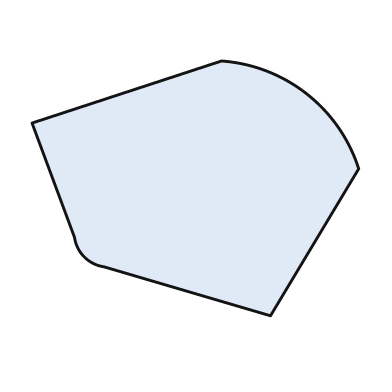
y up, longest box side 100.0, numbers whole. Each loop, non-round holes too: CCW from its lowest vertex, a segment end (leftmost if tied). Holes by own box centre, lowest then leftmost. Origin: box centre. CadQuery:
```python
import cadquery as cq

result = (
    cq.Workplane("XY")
    .moveTo(23.0, -39.0)
    .lineTo(50.0, 6.0)
    .threePointArc((34.0, 29.0), (8.0, 39.0))
    .lineTo(-50.0, 20.0)
    .lineTo(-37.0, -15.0)
    .threePointArc((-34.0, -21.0), (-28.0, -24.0))
    .close()
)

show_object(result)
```